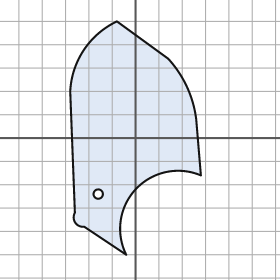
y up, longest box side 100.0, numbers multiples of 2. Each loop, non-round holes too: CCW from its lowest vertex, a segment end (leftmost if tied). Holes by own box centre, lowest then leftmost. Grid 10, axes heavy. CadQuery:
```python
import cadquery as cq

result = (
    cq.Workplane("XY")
    .moveTo(-4.0, -50.0)
    .threePointArc((0.0, -22.0), (28.0, -16.0))
    .lineTo(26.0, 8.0)
    .threePointArc((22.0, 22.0), (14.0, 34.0))
    .lineTo(-8.0, 50.0)
    .threePointArc((-22.0, 38.0), (-28.0, 20.0))
    .lineTo(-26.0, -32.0)
    .threePointArc((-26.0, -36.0), (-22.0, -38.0))
    .close()
    .moveTo(-16.0, -24.0)
    .circle(2.0)
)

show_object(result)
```